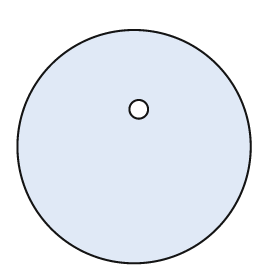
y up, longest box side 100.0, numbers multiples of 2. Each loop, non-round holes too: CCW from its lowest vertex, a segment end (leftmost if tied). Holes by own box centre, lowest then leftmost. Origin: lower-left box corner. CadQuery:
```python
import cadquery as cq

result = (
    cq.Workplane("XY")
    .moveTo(50.0, 50.0)
    .circle(50.0)
    .moveTo(52.0, 66.0)
    .circle(4.0)
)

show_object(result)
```